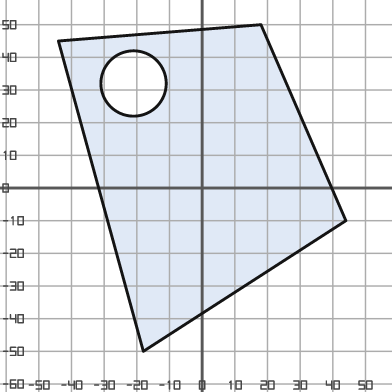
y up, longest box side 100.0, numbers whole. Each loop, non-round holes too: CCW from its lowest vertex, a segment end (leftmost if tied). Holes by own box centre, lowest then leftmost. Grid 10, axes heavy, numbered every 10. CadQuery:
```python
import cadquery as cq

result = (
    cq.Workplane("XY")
    .moveTo(-18.0, -50.0)
    .lineTo(44.0, -10.0)
    .lineTo(18.0, 50.0)
    .lineTo(-44.0, 45.0)
    .close()
    .moveTo(-21.0, 32.0)
    .circle(10.0)
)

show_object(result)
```